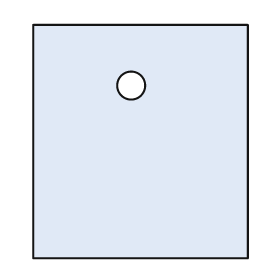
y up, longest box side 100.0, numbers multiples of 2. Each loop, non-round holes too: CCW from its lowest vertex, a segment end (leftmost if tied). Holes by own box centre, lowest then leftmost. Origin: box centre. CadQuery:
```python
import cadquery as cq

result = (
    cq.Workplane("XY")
    .moveTo(-46.0, -50.0)
    .lineTo(46.0, -50.0)
    .lineTo(46.0, 50.0)
    .lineTo(-46.0, 50.0)
    .close()
    .moveTo(-4.0, 24.0)
    .circle(6.0)
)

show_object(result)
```